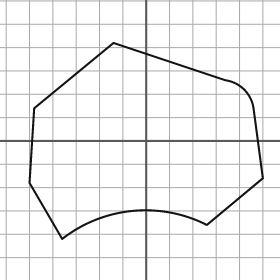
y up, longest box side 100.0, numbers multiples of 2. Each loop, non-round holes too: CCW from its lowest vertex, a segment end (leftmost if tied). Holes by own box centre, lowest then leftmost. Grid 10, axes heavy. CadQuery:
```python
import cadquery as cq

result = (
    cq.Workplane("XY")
    .moveTo(-36.0, -42.0)
    .threePointArc((-6.0, -30.0), (26.0, -36.0))
    .lineTo(50.0, -16.0)
    .lineTo(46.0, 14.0)
    .threePointArc((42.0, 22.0), (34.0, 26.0))
    .lineTo(-14.0, 42.0)
    .lineTo(-48.0, 14.0)
    .lineTo(-50.0, -18.0)
    .close()
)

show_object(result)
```